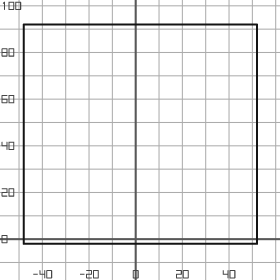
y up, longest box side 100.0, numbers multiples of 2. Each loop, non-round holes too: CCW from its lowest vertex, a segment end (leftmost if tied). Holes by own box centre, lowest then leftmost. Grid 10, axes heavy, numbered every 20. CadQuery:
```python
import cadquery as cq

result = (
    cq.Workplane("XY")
    .moveTo(-48.0, -2.0)
    .lineTo(52.0, -2.0)
    .lineTo(52.0, 92.0)
    .lineTo(-48.0, 92.0)
    .close()
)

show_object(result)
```